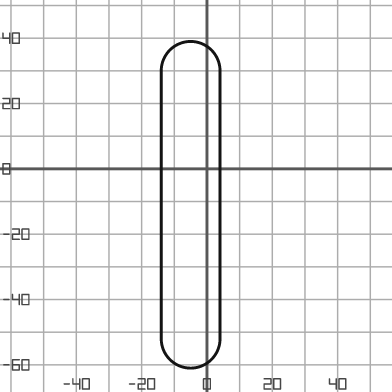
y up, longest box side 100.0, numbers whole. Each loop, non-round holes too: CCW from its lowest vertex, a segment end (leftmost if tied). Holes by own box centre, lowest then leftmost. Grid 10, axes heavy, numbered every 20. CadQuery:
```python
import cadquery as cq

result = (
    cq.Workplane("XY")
    .moveTo(-14.0, -52.0)
    .threePointArc((-5.0, -61.0), (4.0, -52.0))
    .lineTo(4.0, 30.0)
    .threePointArc((-5.0, 39.0), (-14.0, 30.0))
    .close()
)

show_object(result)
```